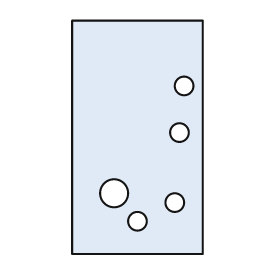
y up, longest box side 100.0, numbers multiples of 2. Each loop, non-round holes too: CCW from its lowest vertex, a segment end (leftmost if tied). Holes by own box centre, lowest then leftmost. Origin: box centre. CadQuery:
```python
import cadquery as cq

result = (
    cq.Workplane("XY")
    .moveTo(-28.0, -50.0)
    .lineTo(28.0, -50.0)
    .lineTo(28.0, 50.0)
    .lineTo(-28.0, 50.0)
    .close()
    .moveTo(0.0, -36.0)
    .circle(4.0)
    .moveTo(16.0, -28.0)
    .circle(4.0)
    .moveTo(-10.0, -24.0)
    .circle(6.0)
    .moveTo(18.0, 2.0)
    .circle(4.0)
    .moveTo(20.0, 22.0)
    .circle(4.0)
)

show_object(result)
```